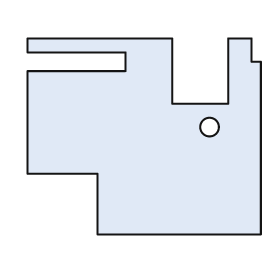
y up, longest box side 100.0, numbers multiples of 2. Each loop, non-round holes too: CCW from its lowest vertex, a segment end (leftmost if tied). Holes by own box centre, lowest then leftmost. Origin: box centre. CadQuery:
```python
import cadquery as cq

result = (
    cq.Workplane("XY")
    .moveTo(-20.0, -42.0)
    .lineTo(50.0, -42.0)
    .lineTo(50.0, 32.0)
    .lineTo(46.0, 32.0)
    .lineTo(46.0, 42.0)
    .lineTo(36.0, 42.0)
    .lineTo(36.0, 14.0)
    .lineTo(12.0, 14.0)
    .lineTo(12.0, 42.0)
    .lineTo(-50.0, 42.0)
    .lineTo(-50.0, 36.0)
    .lineTo(-8.0, 36.0)
    .lineTo(-8.0, 28.0)
    .lineTo(-50.0, 28.0)
    .lineTo(-50.0, -16.0)
    .lineTo(-20.0, -16.0)
    .close()
    .moveTo(28.0, 4.0)
    .circle(4.0)
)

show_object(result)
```